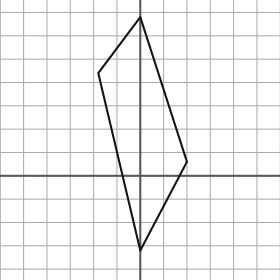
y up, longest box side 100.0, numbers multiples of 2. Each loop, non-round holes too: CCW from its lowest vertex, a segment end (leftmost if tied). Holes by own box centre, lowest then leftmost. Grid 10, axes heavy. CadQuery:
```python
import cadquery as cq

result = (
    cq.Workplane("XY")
    .moveTo(0.0, -32.0)
    .lineTo(20.0, 6.0)
    .lineTo(0.0, 68.0)
    .lineTo(-18.0, 44.0)
    .close()
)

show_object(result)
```